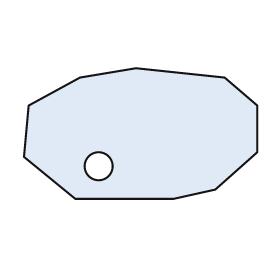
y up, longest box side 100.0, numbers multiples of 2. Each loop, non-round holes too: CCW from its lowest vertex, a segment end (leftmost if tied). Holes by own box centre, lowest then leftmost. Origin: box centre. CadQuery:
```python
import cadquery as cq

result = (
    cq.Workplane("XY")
    .moveTo(-28.0, -28.0)
    .lineTo(14.0, -28.0)
    .lineTo(32.0, -24.0)
    .lineTo(50.0, -8.0)
    .lineTo(50.0, 12.0)
    .lineTo(36.0, 24.0)
    .lineTo(-2.0, 28.0)
    .lineTo(-26.0, 24.0)
    .lineTo(-48.0, 12.0)
    .lineTo(-50.0, -10.0)
    .close()
    .moveTo(-18.0, -14.0)
    .circle(6.0)
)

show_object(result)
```